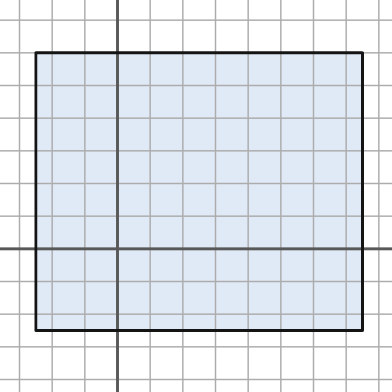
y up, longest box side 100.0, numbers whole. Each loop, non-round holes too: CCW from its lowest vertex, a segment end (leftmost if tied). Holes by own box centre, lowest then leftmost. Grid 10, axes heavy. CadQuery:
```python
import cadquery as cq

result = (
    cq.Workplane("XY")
    .moveTo(-25.0, -25.0)
    .lineTo(75.0, -25.0)
    .lineTo(75.0, 60.0)
    .lineTo(-25.0, 60.0)
    .close()
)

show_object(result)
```